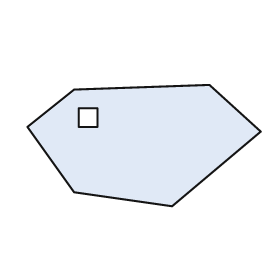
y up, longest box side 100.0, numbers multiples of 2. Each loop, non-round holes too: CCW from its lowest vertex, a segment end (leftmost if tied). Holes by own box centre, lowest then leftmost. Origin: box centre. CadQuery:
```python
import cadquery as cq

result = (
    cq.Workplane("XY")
    .moveTo(12.0, -26.0)
    .lineTo(50.0, 6.0)
    .lineTo(28.0, 26.0)
    .lineTo(-30.0, 24.0)
    .lineTo(-50.0, 8.0)
    .lineTo(-30.0, -20.0)
    .close()
    .moveTo(-28.0, 8.0)
    .lineTo(-20.0, 8.0)
    .lineTo(-20.0, 16.0)
    .lineTo(-28.0, 16.0)
    .close()
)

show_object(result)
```